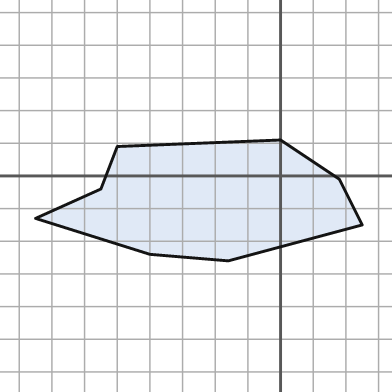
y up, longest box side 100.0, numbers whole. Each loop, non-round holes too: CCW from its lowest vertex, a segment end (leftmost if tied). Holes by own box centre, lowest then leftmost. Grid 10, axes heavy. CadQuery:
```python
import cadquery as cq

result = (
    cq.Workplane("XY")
    .moveTo(-16.0, -26.0)
    .lineTo(25.0, -15.0)
    .lineTo(18.0, -1.0)
    .lineTo(0.0, 11.0)
    .lineTo(-50.0, 9.0)
    .lineTo(-55.0, -4.0)
    .lineTo(-75.0, -13.0)
    .lineTo(-40.0, -24.0)
    .close()
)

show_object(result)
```